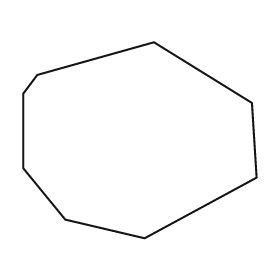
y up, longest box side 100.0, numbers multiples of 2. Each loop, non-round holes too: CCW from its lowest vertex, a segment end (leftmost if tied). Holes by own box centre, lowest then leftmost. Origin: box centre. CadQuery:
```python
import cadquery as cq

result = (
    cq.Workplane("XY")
    .moveTo(2.0, -42.0)
    .lineTo(50.0, -16.0)
    .lineTo(48.0, 16.0)
    .lineTo(6.0, 42.0)
    .lineTo(-44.0, 28.0)
    .lineTo(-50.0, 20.0)
    .lineTo(-50.0, -12.0)
    .lineTo(-32.0, -34.0)
    .close()
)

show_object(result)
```